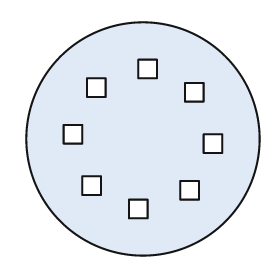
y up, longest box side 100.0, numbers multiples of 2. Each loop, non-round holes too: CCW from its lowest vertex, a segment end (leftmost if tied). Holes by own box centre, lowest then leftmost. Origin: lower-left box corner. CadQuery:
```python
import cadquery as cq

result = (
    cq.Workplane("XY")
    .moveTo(50.0, 50.0)
    .circle(50.0)
    .moveTo(44.0, 16.0)
    .lineTo(52.0, 16.0)
    .lineTo(52.0, 24.0)
    .lineTo(44.0, 24.0)
    .close()
    .moveTo(66.0, 24.0)
    .lineTo(74.0, 24.0)
    .lineTo(74.0, 32.0)
    .lineTo(66.0, 32.0)
    .close()
    .moveTo(24.0, 26.0)
    .lineTo(32.0, 26.0)
    .lineTo(32.0, 34.0)
    .lineTo(24.0, 34.0)
    .close()
    .moveTo(76.0, 44.0)
    .lineTo(84.0, 44.0)
    .lineTo(84.0, 52.0)
    .lineTo(76.0, 52.0)
    .close()
    .moveTo(16.0, 48.0)
    .lineTo(24.0, 48.0)
    .lineTo(24.0, 56.0)
    .lineTo(16.0, 56.0)
    .close()
    .moveTo(68.0, 66.0)
    .lineTo(76.0, 66.0)
    .lineTo(76.0, 74.0)
    .lineTo(68.0, 74.0)
    .close()
    .moveTo(26.0, 68.0)
    .lineTo(34.0, 68.0)
    .lineTo(34.0, 76.0)
    .lineTo(26.0, 76.0)
    .close()
    .moveTo(48.0, 76.0)
    .lineTo(56.0, 76.0)
    .lineTo(56.0, 84.0)
    .lineTo(48.0, 84.0)
    .close()
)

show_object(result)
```